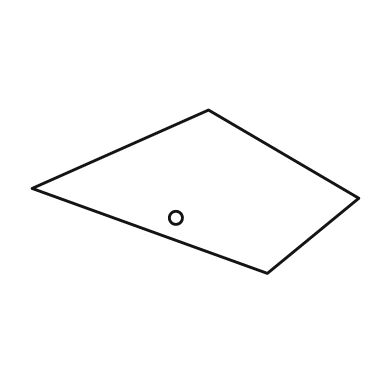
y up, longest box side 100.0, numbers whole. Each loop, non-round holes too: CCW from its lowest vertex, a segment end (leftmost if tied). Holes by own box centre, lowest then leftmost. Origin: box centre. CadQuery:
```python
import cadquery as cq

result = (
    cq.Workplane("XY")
    .moveTo(22.0, -25.0)
    .lineTo(50.0, -2.0)
    .lineTo(4.0, 25.0)
    .lineTo(-50.0, 1.0)
    .close()
    .moveTo(-6.0, -8.0)
    .circle(2.0)
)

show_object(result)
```